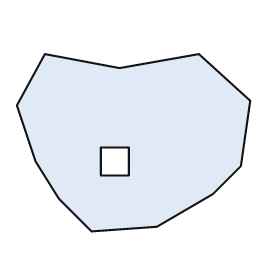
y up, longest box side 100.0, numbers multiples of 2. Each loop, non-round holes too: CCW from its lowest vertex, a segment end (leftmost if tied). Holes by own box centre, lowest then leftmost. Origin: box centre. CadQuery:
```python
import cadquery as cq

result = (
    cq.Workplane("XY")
    .moveTo(-18.0, -38.0)
    .lineTo(10.0, -36.0)
    .lineTo(34.0, -22.0)
    .lineTo(46.0, -10.0)
    .lineTo(50.0, 18.0)
    .lineTo(28.0, 38.0)
    .lineTo(-6.0, 32.0)
    .lineTo(-38.0, 38.0)
    .lineTo(-50.0, 16.0)
    .lineTo(-42.0, -8.0)
    .lineTo(-32.0, -24.0)
    .close()
    .moveTo(-14.0, -14.0)
    .lineTo(-2.0, -14.0)
    .lineTo(-2.0, -2.0)
    .lineTo(-14.0, -2.0)
    .close()
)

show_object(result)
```